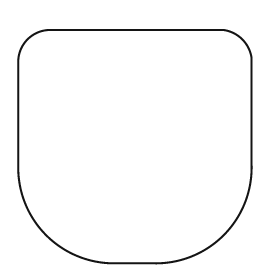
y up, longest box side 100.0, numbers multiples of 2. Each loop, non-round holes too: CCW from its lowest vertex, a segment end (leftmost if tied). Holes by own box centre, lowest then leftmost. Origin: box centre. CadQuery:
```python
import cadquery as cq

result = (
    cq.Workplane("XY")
    .moveTo(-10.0, -50.0)
    .lineTo(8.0, -50.0)
    .threePointArc((38.0, -38.0), (50.0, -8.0))
    .lineTo(50.0, 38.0)
    .threePointArc((46.0, 46.0), (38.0, 50.0))
    .lineTo(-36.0, 50.0)
    .threePointArc((-46.0, 46.0), (-50.0, 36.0))
    .lineTo(-50.0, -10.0)
    .threePointArc((-38.0, -38.0), (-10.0, -50.0))
    .close()
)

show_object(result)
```